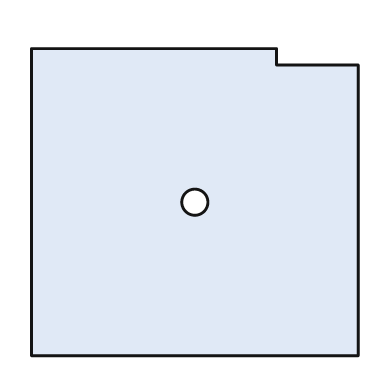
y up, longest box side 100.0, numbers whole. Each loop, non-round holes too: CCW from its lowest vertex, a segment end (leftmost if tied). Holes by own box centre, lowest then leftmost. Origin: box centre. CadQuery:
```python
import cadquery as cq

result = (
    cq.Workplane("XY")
    .moveTo(-50.0, -47.0)
    .lineTo(50.0, -47.0)
    .lineTo(50.0, 42.0)
    .lineTo(25.0, 42.0)
    .lineTo(25.0, 47.0)
    .lineTo(-50.0, 47.0)
    .close()
    .moveTo(0.0, 0.0)
    .circle(4.0)
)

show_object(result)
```